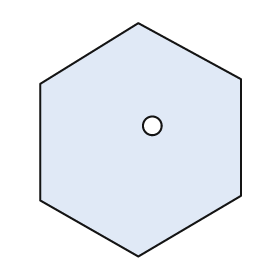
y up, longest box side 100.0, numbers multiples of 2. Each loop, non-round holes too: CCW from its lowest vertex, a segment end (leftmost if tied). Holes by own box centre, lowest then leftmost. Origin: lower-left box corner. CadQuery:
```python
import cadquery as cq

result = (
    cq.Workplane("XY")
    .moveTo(42.0, 0.0)
    .lineTo(86.0, 26.0)
    .lineTo(86.0, 76.0)
    .lineTo(42.0, 100.0)
    .lineTo(0.0, 74.0)
    .lineTo(0.0, 24.0)
    .close()
    .moveTo(48.0, 56.0)
    .circle(4.0)
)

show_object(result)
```